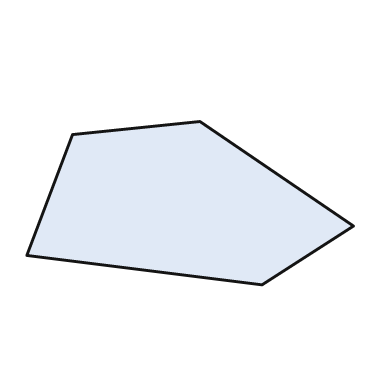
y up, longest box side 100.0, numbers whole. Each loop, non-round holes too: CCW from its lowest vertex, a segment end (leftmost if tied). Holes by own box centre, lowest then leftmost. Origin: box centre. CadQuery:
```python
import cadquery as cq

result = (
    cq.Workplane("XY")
    .moveTo(22.0, -25.0)
    .lineTo(50.0, -7.0)
    .lineTo(3.0, 25.0)
    .lineTo(-36.0, 21.0)
    .lineTo(-50.0, -16.0)
    .close()
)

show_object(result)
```